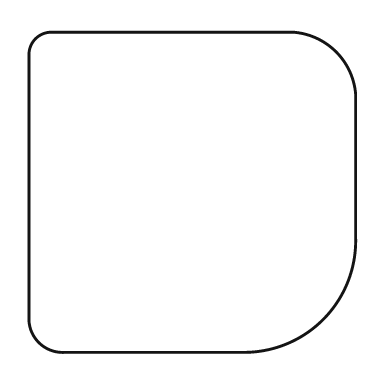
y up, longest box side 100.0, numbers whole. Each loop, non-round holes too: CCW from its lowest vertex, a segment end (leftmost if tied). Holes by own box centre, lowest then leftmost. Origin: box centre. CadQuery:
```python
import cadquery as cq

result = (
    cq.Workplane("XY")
    .moveTo(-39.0, -49.0)
    .lineTo(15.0, -49.0)
    .threePointArc((40.0, -39.0), (50.0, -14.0))
    .lineTo(50.0, 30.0)
    .threePointArc((44.0, 43.0), (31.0, 49.0))
    .lineTo(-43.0, 49.0)
    .threePointArc((-48.0, 47.0), (-50.0, 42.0))
    .lineTo(-50.0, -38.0)
    .threePointArc((-47.0, -46.0), (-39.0, -49.0))
    .close()
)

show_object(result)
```